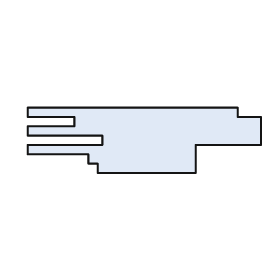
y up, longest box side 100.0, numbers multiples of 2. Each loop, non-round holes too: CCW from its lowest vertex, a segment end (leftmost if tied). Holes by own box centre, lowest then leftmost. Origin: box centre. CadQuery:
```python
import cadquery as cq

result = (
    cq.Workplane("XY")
    .moveTo(-20.0, -14.0)
    .lineTo(22.0, -14.0)
    .lineTo(22.0, -2.0)
    .lineTo(50.0, -2.0)
    .lineTo(50.0, 10.0)
    .lineTo(40.0, 10.0)
    .lineTo(40.0, 14.0)
    .lineTo(-50.0, 14.0)
    .lineTo(-50.0, 10.0)
    .lineTo(-30.0, 10.0)
    .lineTo(-30.0, 6.0)
    .lineTo(-50.0, 6.0)
    .lineTo(-50.0, 2.0)
    .lineTo(-18.0, 2.0)
    .lineTo(-18.0, -2.0)
    .lineTo(-50.0, -2.0)
    .lineTo(-50.0, -6.0)
    .lineTo(-24.0, -6.0)
    .lineTo(-24.0, -10.0)
    .lineTo(-20.0, -10.0)
    .close()
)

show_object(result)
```